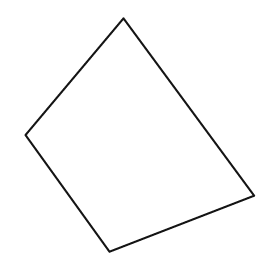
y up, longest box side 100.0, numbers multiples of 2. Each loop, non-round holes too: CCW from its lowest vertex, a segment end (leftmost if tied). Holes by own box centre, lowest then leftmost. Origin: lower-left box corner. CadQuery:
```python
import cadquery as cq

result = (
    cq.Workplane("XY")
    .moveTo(36.0, 0.0)
    .lineTo(98.0, 24.0)
    .lineTo(42.0, 100.0)
    .lineTo(0.0, 50.0)
    .close()
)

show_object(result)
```